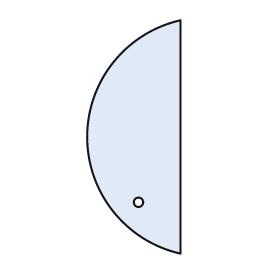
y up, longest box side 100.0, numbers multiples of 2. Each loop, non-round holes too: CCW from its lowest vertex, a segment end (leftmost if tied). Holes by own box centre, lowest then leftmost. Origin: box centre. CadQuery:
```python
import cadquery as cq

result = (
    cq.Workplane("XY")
    .moveTo(20.0, -50.0)
    .lineTo(20.0, 50.0)
    .threePointArc((-20.0, 0.0), (20.0, -50.0))
    .close()
    .moveTo(2.0, -28.0)
    .circle(2.0)
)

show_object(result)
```